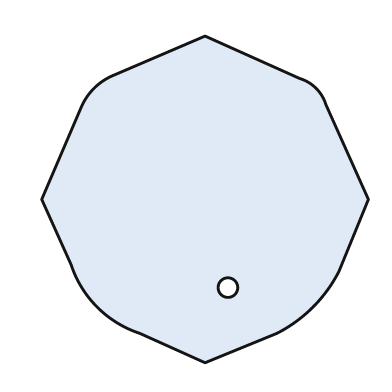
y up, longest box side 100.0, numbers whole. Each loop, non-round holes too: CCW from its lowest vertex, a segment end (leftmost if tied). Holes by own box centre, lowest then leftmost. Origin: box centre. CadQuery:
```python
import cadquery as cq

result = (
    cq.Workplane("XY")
    .moveTo(0.0, -50.0)
    .lineTo(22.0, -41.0)
    .threePointArc((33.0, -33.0), (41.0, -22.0))
    .lineTo(50.0, 0.0)
    .lineTo(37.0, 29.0)
    .threePointArc((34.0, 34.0), (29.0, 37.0))
    .lineTo(0.0, 50.0)
    .lineTo(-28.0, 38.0)
    .threePointArc((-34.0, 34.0), (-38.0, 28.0))
    .lineTo(-50.0, 0.0)
    .lineTo(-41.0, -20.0)
    .threePointArc((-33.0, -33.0), (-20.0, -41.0))
    .close()
    .moveTo(7.0, -27.0)
    .circle(3.0)
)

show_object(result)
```